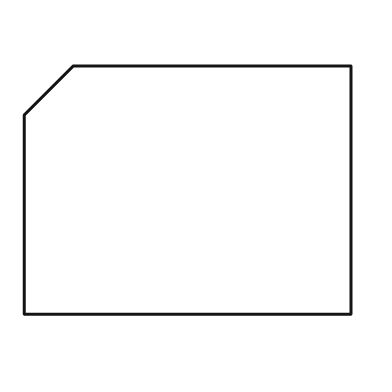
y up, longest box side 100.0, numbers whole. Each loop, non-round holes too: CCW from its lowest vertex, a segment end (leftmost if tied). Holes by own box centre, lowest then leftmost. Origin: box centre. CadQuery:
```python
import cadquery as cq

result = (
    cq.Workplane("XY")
    .moveTo(-50.0, -38.0)
    .lineTo(50.0, -38.0)
    .lineTo(50.0, 38.0)
    .lineTo(-35.0, 38.0)
    .lineTo(-50.0, 23.0)
    .close()
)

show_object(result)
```